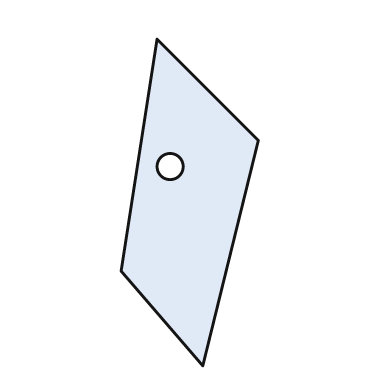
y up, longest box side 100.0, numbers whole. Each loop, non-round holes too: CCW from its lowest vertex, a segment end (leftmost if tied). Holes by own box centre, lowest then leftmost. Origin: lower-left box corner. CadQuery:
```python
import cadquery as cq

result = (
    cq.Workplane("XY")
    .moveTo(25.0, 0.0)
    .lineTo(42.0, 69.0)
    .lineTo(11.0, 100.0)
    .lineTo(0.0, 29.0)
    .close()
    .moveTo(15.0, 61.0)
    .circle(4.0)
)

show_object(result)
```